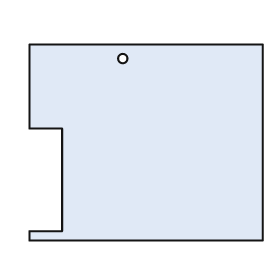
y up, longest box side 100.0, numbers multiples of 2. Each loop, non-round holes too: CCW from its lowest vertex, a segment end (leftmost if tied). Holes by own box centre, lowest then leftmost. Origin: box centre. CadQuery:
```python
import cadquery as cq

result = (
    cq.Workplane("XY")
    .moveTo(-50.0, -42.0)
    .lineTo(50.0, -42.0)
    .lineTo(50.0, 42.0)
    .lineTo(-50.0, 42.0)
    .lineTo(-50.0, 6.0)
    .lineTo(-36.0, 6.0)
    .lineTo(-36.0, -38.0)
    .lineTo(-50.0, -38.0)
    .close()
    .moveTo(-10.0, 36.0)
    .circle(2.0)
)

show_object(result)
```